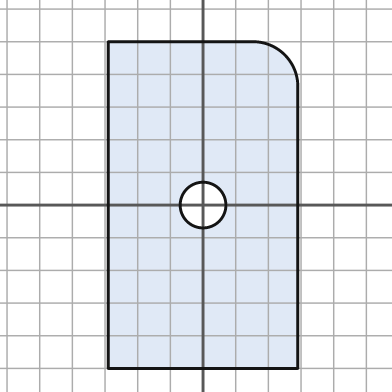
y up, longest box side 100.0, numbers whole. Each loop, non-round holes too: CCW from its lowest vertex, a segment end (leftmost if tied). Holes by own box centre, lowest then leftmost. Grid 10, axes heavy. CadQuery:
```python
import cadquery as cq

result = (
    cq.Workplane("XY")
    .moveTo(-29.0, -50.0)
    .lineTo(29.0, -50.0)
    .lineTo(29.0, 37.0)
    .threePointArc((25.0, 46.0), (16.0, 50.0))
    .lineTo(-29.0, 50.0)
    .close()
    .moveTo(0.0, 0.0)
    .circle(7.0)
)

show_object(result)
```